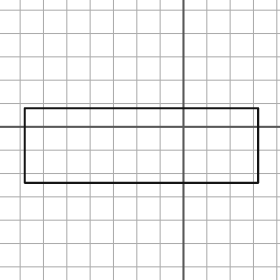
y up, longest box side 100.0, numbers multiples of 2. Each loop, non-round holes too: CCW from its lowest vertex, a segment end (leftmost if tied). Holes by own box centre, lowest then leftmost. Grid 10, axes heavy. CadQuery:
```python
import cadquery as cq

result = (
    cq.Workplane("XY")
    .moveTo(-68.0, -24.0)
    .lineTo(32.0, -24.0)
    .lineTo(32.0, 8.0)
    .lineTo(-68.0, 8.0)
    .close()
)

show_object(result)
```